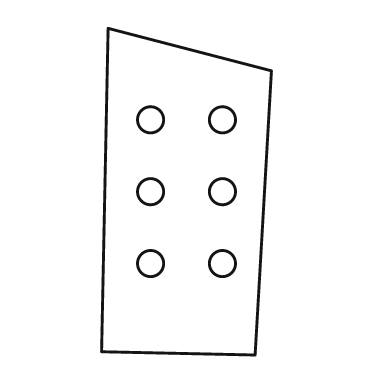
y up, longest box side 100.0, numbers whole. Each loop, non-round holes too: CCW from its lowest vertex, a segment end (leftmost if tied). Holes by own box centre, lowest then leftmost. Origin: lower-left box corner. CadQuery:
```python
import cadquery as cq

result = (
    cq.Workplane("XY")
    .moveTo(47.0, 0.0)
    .lineTo(52.0, 87.0)
    .lineTo(2.0, 100.0)
    .lineTo(0.0, 1.0)
    .close()
    .moveTo(15.0, 28.0)
    .circle(4.0)
    .moveTo(37.0, 28.0)
    .circle(4.0)
    .moveTo(15.0, 50.0)
    .circle(4.0)
    .moveTo(37.0, 50.0)
    .circle(4.0)
    .moveTo(15.0, 72.0)
    .circle(4.0)
    .moveTo(37.0, 72.0)
    .circle(4.0)
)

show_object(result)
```